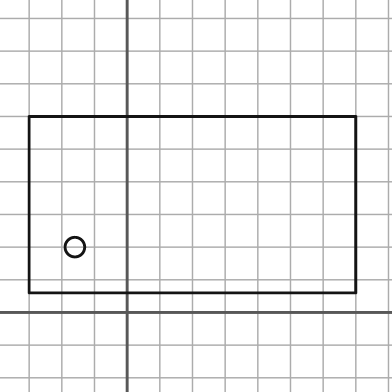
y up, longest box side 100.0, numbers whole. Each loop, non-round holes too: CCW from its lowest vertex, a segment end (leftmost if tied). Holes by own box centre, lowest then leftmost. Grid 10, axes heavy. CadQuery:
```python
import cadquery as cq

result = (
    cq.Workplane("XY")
    .moveTo(-30.0, 6.0)
    .lineTo(70.0, 6.0)
    .lineTo(70.0, 60.0)
    .lineTo(-30.0, 60.0)
    .close()
    .moveTo(-16.0, 20.0)
    .circle(3.0)
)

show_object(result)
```